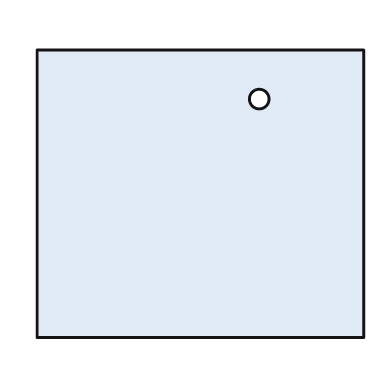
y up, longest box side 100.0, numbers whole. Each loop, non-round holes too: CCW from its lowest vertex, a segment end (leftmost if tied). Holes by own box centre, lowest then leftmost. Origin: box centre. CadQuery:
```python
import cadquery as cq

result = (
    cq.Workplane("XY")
    .moveTo(-50.0, -44.0)
    .lineTo(50.0, -44.0)
    .lineTo(50.0, 44.0)
    .lineTo(-50.0, 44.0)
    .close()
    .moveTo(18.0, 29.0)
    .circle(3.0)
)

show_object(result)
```